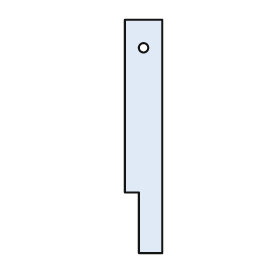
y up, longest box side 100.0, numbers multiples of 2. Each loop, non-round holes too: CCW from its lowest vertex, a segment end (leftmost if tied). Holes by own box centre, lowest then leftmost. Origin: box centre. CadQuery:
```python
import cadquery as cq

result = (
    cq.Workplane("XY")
    .moveTo(-2.0, -50.0)
    .lineTo(8.0, -50.0)
    .lineTo(8.0, 50.0)
    .lineTo(-8.0, 50.0)
    .lineTo(-8.0, -24.0)
    .lineTo(-2.0, -24.0)
    .close()
    .moveTo(0.0, 38.0)
    .circle(2.0)
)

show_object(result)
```